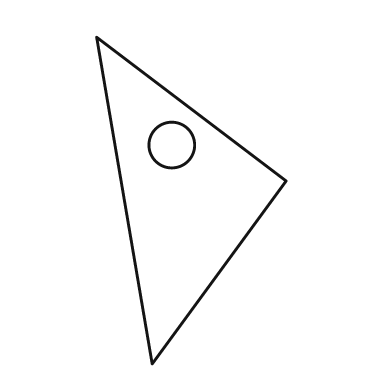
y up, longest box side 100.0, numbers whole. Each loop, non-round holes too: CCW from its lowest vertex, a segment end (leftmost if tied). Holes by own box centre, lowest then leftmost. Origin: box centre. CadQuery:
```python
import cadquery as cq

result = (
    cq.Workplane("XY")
    .moveTo(-12.0, -50.0)
    .lineTo(29.0, 6.0)
    .lineTo(-29.0, 50.0)
    .close()
    .moveTo(-6.0, 17.0)
    .circle(7.0)
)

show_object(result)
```